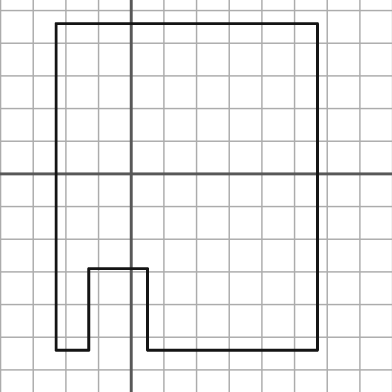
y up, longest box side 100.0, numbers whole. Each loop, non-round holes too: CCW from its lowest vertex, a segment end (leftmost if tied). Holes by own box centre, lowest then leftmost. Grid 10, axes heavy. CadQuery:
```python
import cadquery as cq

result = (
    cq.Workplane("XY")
    .moveTo(-23.0, -54.0)
    .lineTo(-13.0, -54.0)
    .lineTo(-13.0, -29.0)
    .lineTo(5.0, -29.0)
    .lineTo(5.0, -54.0)
    .lineTo(57.0, -54.0)
    .lineTo(57.0, 46.0)
    .lineTo(-23.0, 46.0)
    .close()
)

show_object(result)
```